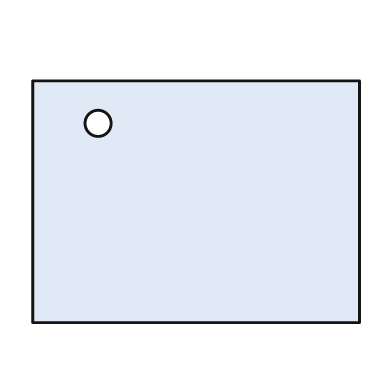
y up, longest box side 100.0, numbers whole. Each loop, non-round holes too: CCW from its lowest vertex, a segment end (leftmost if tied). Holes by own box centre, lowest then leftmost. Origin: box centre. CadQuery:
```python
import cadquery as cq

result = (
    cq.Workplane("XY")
    .moveTo(-50.0, -37.0)
    .lineTo(50.0, -37.0)
    .lineTo(50.0, 37.0)
    .lineTo(-50.0, 37.0)
    .close()
    .moveTo(-30.0, 24.0)
    .circle(4.0)
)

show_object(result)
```